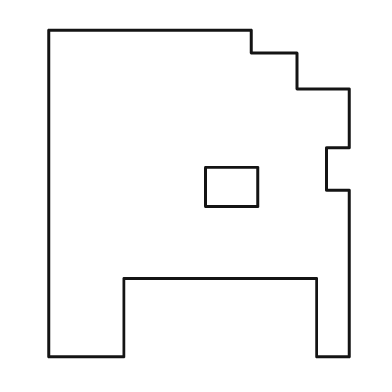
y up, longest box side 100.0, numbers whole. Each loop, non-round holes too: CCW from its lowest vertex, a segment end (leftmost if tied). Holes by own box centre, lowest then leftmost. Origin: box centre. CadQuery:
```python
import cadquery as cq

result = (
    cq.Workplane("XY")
    .moveTo(-46.0, -50.0)
    .lineTo(-23.0, -50.0)
    .lineTo(-23.0, -26.0)
    .lineTo(36.0, -26.0)
    .lineTo(36.0, -50.0)
    .lineTo(46.0, -50.0)
    .lineTo(46.0, 1.0)
    .lineTo(39.0, 1.0)
    .lineTo(39.0, 14.0)
    .lineTo(46.0, 14.0)
    .lineTo(46.0, 32.0)
    .lineTo(30.0, 32.0)
    .lineTo(30.0, 43.0)
    .lineTo(16.0, 43.0)
    .lineTo(16.0, 50.0)
    .lineTo(-46.0, 50.0)
    .close()
    .moveTo(2.0, -4.0)
    .lineTo(18.0, -4.0)
    .lineTo(18.0, 8.0)
    .lineTo(2.0, 8.0)
    .close()
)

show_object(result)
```